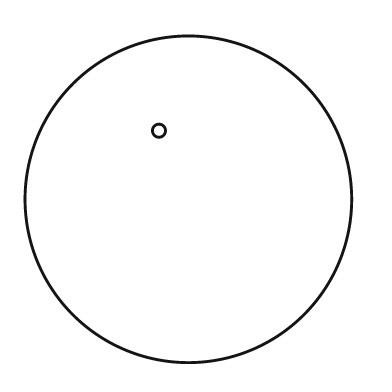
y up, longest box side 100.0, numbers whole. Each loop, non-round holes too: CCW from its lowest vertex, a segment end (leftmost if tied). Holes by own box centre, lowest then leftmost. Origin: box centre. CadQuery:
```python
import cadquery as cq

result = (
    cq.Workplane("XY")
    .moveTo(0.0, 0.0)
    .circle(50.0)
    .moveTo(-9.0, 21.0)
    .circle(2.0)
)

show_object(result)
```